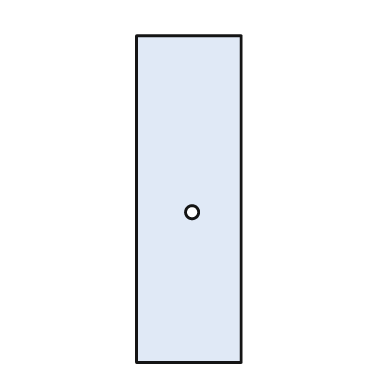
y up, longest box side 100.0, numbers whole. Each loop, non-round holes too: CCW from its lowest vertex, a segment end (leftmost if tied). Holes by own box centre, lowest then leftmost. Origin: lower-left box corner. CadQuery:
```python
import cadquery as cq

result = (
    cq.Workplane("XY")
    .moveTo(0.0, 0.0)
    .lineTo(32.0, 0.0)
    .lineTo(32.0, 100.0)
    .lineTo(0.0, 100.0)
    .close()
    .moveTo(17.0, 46.0)
    .circle(2.0)
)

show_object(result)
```